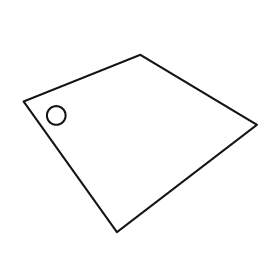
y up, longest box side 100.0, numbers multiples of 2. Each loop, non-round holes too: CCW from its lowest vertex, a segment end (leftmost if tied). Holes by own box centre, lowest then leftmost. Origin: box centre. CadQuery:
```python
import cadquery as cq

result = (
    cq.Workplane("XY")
    .moveTo(-10.0, -38.0)
    .lineTo(50.0, 8.0)
    .lineTo(0.0, 38.0)
    .lineTo(-50.0, 18.0)
    .close()
    .moveTo(-36.0, 12.0)
    .circle(4.0)
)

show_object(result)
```